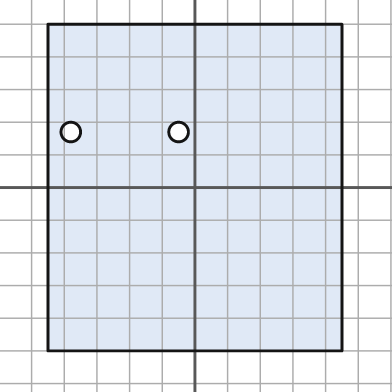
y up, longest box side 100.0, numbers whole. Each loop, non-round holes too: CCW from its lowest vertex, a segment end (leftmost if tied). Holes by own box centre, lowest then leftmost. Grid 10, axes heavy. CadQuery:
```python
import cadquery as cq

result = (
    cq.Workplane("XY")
    .moveTo(-45.0, -50.0)
    .lineTo(45.0, -50.0)
    .lineTo(45.0, 50.0)
    .lineTo(-45.0, 50.0)
    .close()
    .moveTo(-38.0, 17.0)
    .circle(3.0)
    .moveTo(-5.0, 17.0)
    .circle(3.0)
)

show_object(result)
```